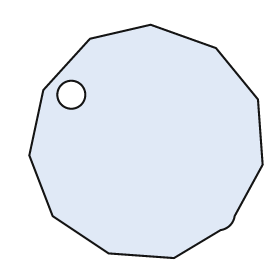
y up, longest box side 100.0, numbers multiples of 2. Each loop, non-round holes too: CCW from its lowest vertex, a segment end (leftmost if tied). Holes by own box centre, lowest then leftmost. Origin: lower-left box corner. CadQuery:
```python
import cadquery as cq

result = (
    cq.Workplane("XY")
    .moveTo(62.0, 0.0)
    .lineTo(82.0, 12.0)
    .threePointArc((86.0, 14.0), (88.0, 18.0))
    .lineTo(100.0, 40.0)
    .lineTo(98.0, 68.0)
    .lineTo(80.0, 90.0)
    .lineTo(52.0, 100.0)
    .lineTo(26.0, 94.0)
    .lineTo(6.0, 72.0)
    .lineTo(0.0, 44.0)
    .lineTo(10.0, 18.0)
    .lineTo(34.0, 2.0)
    .close()
    .moveTo(18.0, 70.0)
    .circle(6.0)
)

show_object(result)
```